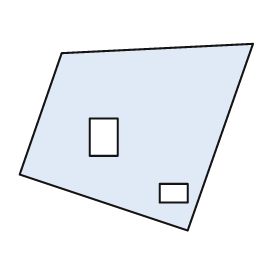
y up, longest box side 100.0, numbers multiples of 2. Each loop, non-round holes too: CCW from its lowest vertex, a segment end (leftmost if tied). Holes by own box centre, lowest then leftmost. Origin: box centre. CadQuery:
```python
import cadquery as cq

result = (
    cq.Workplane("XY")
    .moveTo(22.0, -40.0)
    .lineTo(50.0, 40.0)
    .lineTo(-32.0, 36.0)
    .lineTo(-50.0, -16.0)
    .close()
    .moveTo(10.0, -28.0)
    .lineTo(22.0, -28.0)
    .lineTo(22.0, -20.0)
    .lineTo(10.0, -20.0)
    .close()
    .moveTo(-20.0, -8.0)
    .lineTo(-8.0, -8.0)
    .lineTo(-8.0, 8.0)
    .lineTo(-20.0, 8.0)
    .close()
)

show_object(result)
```